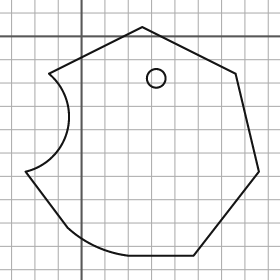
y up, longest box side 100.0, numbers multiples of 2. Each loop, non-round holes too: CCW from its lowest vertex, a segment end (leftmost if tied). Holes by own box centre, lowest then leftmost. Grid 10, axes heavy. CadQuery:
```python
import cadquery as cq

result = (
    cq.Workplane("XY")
    .moveTo(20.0, -94.0)
    .lineTo(48.0, -94.0)
    .lineTo(76.0, -58.0)
    .lineTo(66.0, -16.0)
    .lineTo(26.0, 4.0)
    .lineTo(-14.0, -16.0)
    .threePointArc((-6.0, -40.0), (-24.0, -58.0))
    .lineTo(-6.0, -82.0)
    .threePointArc((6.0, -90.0), (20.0, -94.0))
    .close()
    .moveTo(32.0, -18.0)
    .circle(4.0)
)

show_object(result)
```